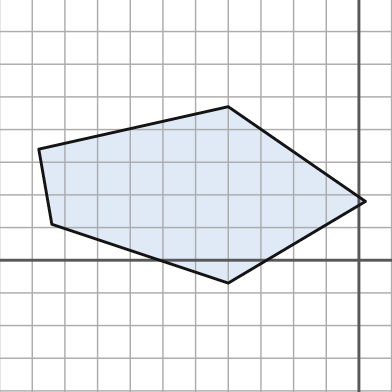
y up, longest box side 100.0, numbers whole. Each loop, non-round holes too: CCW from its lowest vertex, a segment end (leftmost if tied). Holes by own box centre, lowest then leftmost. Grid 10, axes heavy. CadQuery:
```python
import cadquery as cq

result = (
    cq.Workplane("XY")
    .moveTo(-40.0, -7.0)
    .lineTo(2.0, 18.0)
    .lineTo(-40.0, 47.0)
    .lineTo(-98.0, 34.0)
    .lineTo(-94.0, 11.0)
    .close()
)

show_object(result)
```